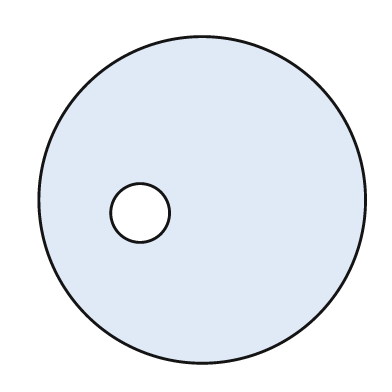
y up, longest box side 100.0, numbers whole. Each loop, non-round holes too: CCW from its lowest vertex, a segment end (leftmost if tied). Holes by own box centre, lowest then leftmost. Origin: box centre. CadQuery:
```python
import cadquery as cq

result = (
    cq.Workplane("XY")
    .moveTo(0.0, 0.0)
    .circle(50.0)
    .moveTo(-19.0, -4.0)
    .circle(9.0)
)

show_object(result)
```